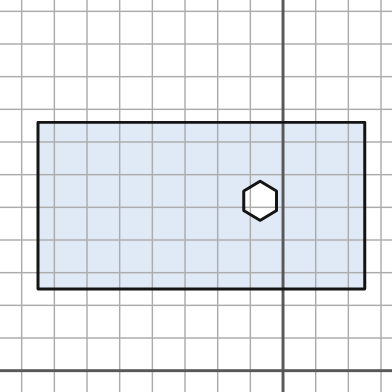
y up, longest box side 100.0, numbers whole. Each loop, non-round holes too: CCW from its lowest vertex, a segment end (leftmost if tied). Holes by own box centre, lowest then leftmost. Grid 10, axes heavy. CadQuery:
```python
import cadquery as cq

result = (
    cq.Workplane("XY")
    .moveTo(-75.0, 25.0)
    .lineTo(25.0, 25.0)
    .lineTo(25.0, 76.0)
    .lineTo(-75.0, 76.0)
    .close()
    .moveTo(-7.0, 46.0)
    .lineTo(-2.0, 49.0)
    .lineTo(-2.0, 55.0)
    .lineTo(-7.0, 58.0)
    .lineTo(-12.0, 55.0)
    .lineTo(-12.0, 49.0)
    .close()
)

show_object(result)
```